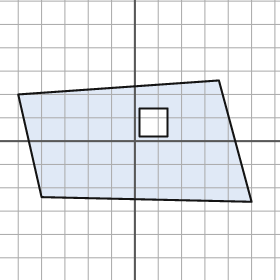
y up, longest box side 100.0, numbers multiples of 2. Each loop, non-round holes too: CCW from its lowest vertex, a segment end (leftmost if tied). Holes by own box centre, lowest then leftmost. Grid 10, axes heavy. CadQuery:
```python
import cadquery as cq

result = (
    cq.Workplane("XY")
    .moveTo(50.0, -26.0)
    .lineTo(36.0, 26.0)
    .lineTo(-50.0, 20.0)
    .lineTo(-40.0, -24.0)
    .close()
    .moveTo(2.0, 2.0)
    .lineTo(14.0, 2.0)
    .lineTo(14.0, 14.0)
    .lineTo(2.0, 14.0)
    .close()
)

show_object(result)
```